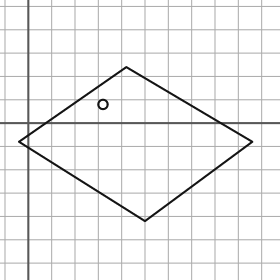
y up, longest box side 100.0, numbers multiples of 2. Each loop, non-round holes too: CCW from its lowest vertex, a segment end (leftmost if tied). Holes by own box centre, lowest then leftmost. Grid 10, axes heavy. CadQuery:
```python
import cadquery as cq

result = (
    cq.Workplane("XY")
    .moveTo(50.0, -42.0)
    .lineTo(96.0, -8.0)
    .lineTo(42.0, 24.0)
    .lineTo(-4.0, -8.0)
    .close()
    .moveTo(32.0, 8.0)
    .circle(2.0)
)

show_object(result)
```